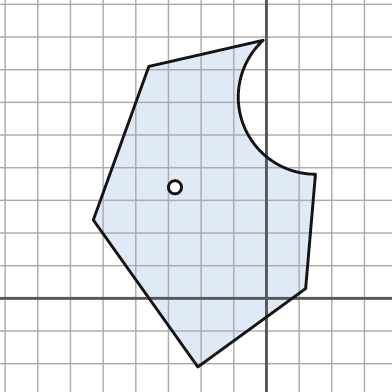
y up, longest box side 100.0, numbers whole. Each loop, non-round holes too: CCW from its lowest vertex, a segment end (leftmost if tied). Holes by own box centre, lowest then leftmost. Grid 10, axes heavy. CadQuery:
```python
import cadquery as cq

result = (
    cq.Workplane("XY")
    .moveTo(-21.0, -21.0)
    .lineTo(12.0, 3.0)
    .lineTo(15.0, 38.0)
    .threePointArc((-7.0, 53.0), (-1.0, 79.0))
    .lineTo(-36.0, 71.0)
    .lineTo(-53.0, 24.0)
    .close()
    .moveTo(-28.0, 34.0)
    .circle(2.0)
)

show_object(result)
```